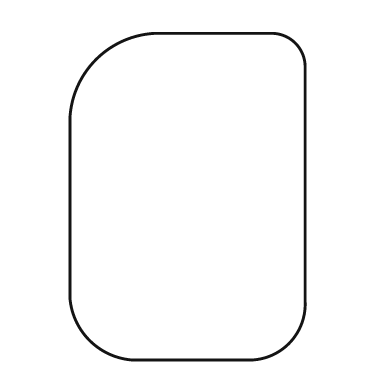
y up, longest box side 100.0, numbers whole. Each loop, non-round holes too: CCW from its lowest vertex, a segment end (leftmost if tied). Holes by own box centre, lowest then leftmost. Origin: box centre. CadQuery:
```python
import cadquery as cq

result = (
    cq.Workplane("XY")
    .moveTo(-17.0, -50.0)
    .lineTo(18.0, -50.0)
    .threePointArc((31.0, -45.0), (36.0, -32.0))
    .lineTo(36.0, 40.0)
    .threePointArc((33.0, 47.0), (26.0, 50.0))
    .lineTo(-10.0, 50.0)
    .threePointArc((-28.0, 42.0), (-36.0, 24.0))
    .lineTo(-36.0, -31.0)
    .threePointArc((-30.0, -44.0), (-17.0, -50.0))
    .close()
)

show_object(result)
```